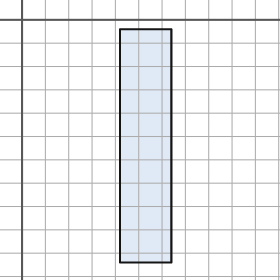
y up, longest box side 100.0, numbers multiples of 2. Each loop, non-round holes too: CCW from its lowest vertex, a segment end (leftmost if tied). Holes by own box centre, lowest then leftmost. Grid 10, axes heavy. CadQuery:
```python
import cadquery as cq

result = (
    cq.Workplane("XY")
    .moveTo(42.0, -104.0)
    .lineTo(64.0, -104.0)
    .lineTo(64.0, -4.0)
    .lineTo(42.0, -4.0)
    .close()
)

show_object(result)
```